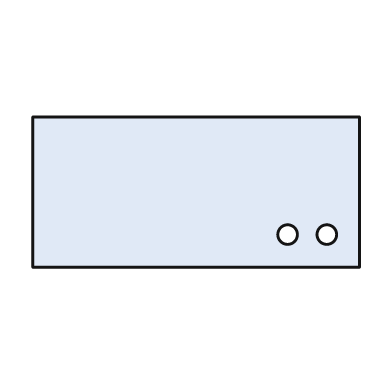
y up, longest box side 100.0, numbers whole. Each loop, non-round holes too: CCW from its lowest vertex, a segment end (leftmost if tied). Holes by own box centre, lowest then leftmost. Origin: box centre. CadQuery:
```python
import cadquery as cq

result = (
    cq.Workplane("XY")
    .moveTo(-50.0, -23.0)
    .lineTo(50.0, -23.0)
    .lineTo(50.0, 23.0)
    .lineTo(-50.0, 23.0)
    .close()
    .moveTo(28.0, -13.0)
    .circle(3.0)
    .moveTo(40.0, -13.0)
    .circle(3.0)
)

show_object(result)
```